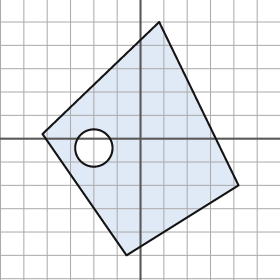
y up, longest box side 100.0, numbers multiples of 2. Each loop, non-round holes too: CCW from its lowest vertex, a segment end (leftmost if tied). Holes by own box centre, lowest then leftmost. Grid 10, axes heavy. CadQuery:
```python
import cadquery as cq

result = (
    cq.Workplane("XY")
    .moveTo(-6.0, -50.0)
    .lineTo(42.0, -20.0)
    .lineTo(8.0, 50.0)
    .lineTo(-42.0, 2.0)
    .close()
    .moveTo(-20.0, -4.0)
    .circle(8.0)
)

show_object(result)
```